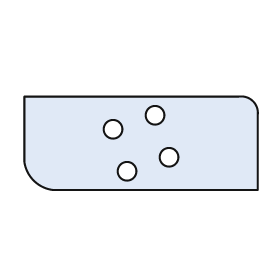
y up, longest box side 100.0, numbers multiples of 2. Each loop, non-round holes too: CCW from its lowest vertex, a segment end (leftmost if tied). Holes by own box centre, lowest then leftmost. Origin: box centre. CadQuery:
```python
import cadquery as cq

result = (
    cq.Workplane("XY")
    .moveTo(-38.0, -20.0)
    .lineTo(50.0, -20.0)
    .lineTo(50.0, 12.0)
    .threePointArc((48.0, 18.0), (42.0, 20.0))
    .lineTo(-50.0, 20.0)
    .lineTo(-50.0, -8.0)
    .threePointArc((-46.0, -16.0), (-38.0, -20.0))
    .close()
    .moveTo(-6.0, -12.0)
    .circle(4.0)
    .moveTo(12.0, -6.0)
    .circle(4.0)
    .moveTo(-12.0, 6.0)
    .circle(4.0)
    .moveTo(6.0, 12.0)
    .circle(4.0)
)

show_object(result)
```